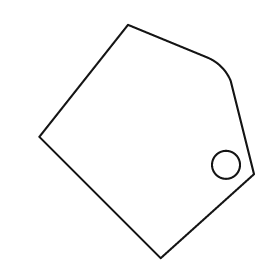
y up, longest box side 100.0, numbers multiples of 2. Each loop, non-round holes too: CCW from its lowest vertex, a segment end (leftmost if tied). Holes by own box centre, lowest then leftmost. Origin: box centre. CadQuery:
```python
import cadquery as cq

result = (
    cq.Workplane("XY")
    .moveTo(6.0, -50.0)
    .lineTo(46.0, -14.0)
    .lineTo(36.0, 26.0)
    .threePointArc((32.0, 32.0), (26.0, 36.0))
    .lineTo(-8.0, 50.0)
    .lineTo(-46.0, 2.0)
    .close()
    .moveTo(34.0, -10.0)
    .circle(6.0)
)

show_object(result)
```